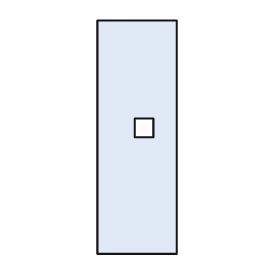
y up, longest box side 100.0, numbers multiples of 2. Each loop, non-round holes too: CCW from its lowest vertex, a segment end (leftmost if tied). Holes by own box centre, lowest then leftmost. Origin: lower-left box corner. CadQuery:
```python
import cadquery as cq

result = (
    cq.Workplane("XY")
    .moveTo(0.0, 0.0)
    .lineTo(34.0, 0.0)
    .lineTo(34.0, 100.0)
    .lineTo(0.0, 100.0)
    .close()
    .moveTo(16.0, 50.0)
    .lineTo(24.0, 50.0)
    .lineTo(24.0, 58.0)
    .lineTo(16.0, 58.0)
    .close()
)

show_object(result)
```